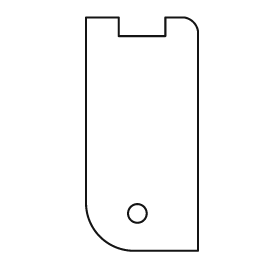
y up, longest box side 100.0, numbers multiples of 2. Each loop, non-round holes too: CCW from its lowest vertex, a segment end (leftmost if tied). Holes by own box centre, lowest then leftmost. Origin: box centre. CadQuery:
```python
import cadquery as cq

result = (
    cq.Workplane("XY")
    .moveTo(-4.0, -50.0)
    .lineTo(24.0, -50.0)
    .lineTo(24.0, 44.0)
    .threePointArc((22.0, 48.0), (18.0, 50.0))
    .lineTo(10.0, 50.0)
    .lineTo(10.0, 42.0)
    .lineTo(-10.0, 42.0)
    .lineTo(-10.0, 50.0)
    .lineTo(-24.0, 50.0)
    .lineTo(-24.0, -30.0)
    .threePointArc((-18.0, -44.0), (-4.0, -50.0))
    .close()
    .moveTo(-2.0, -34.0)
    .circle(4.0)
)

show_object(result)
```